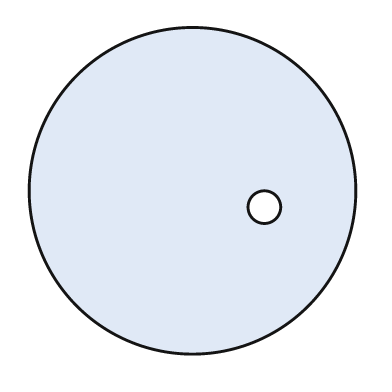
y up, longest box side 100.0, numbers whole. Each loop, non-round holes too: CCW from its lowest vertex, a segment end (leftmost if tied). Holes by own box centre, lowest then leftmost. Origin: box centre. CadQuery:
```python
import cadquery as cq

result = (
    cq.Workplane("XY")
    .moveTo(0.0, 0.0)
    .circle(50.0)
    .moveTo(22.0, -5.0)
    .circle(5.0)
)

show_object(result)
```